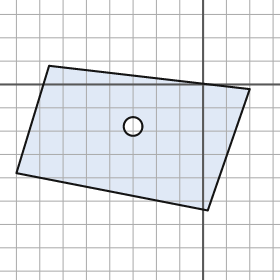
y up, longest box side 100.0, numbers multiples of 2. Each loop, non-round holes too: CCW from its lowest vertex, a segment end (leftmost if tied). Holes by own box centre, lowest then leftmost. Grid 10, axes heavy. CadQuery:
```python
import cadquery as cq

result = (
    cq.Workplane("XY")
    .moveTo(2.0, -54.0)
    .lineTo(20.0, -2.0)
    .lineTo(-66.0, 8.0)
    .lineTo(-80.0, -38.0)
    .close()
    .moveTo(-30.0, -18.0)
    .circle(4.0)
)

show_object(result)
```